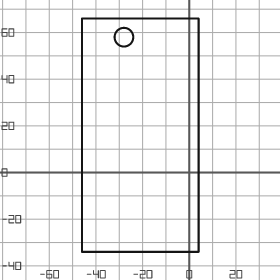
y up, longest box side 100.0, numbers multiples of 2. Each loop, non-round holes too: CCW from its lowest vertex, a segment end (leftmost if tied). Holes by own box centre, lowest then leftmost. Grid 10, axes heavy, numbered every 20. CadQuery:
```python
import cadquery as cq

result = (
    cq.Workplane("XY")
    .moveTo(-46.0, -34.0)
    .lineTo(4.0, -34.0)
    .lineTo(4.0, 66.0)
    .lineTo(-46.0, 66.0)
    .close()
    .moveTo(-28.0, 58.0)
    .circle(4.0)
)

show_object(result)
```